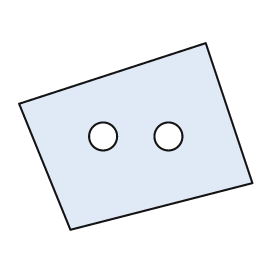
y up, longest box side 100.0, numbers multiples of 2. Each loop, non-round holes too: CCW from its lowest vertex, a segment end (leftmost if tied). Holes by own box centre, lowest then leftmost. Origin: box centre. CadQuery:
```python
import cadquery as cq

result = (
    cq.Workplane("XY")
    .moveTo(-28.0, -40.0)
    .lineTo(50.0, -20.0)
    .lineTo(30.0, 40.0)
    .lineTo(-50.0, 14.0)
    .close()
    .moveTo(-14.0, 0.0)
    .circle(6.0)
    .moveTo(14.0, 0.0)
    .circle(6.0)
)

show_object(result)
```